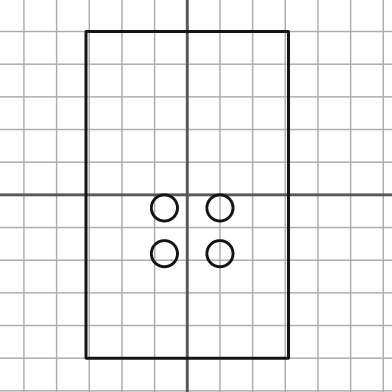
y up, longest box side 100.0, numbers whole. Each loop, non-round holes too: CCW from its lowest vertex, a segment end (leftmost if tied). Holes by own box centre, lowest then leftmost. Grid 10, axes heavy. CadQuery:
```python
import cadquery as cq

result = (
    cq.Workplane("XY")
    .moveTo(-31.0, -50.0)
    .lineTo(31.0, -50.0)
    .lineTo(31.0, 50.0)
    .lineTo(-31.0, 50.0)
    .close()
    .moveTo(-7.0, -18.0)
    .circle(4.0)
    .moveTo(10.0, -18.0)
    .circle(4.0)
    .moveTo(-7.0, -4.0)
    .circle(4.0)
    .moveTo(10.0, -4.0)
    .circle(4.0)
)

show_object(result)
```